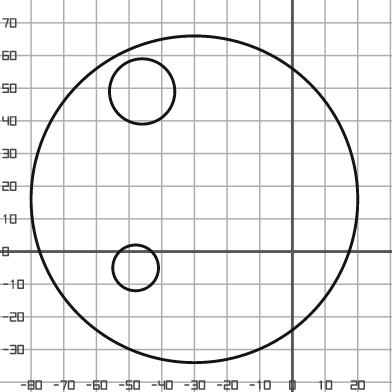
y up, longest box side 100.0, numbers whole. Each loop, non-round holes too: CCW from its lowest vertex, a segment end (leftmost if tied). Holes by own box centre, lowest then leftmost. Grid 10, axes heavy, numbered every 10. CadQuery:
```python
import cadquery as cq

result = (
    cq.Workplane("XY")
    .moveTo(-30.0, 16.0)
    .circle(50.0)
    .moveTo(-48.0, -5.0)
    .circle(7.0)
    .moveTo(-46.0, 49.0)
    .circle(10.0)
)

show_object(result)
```